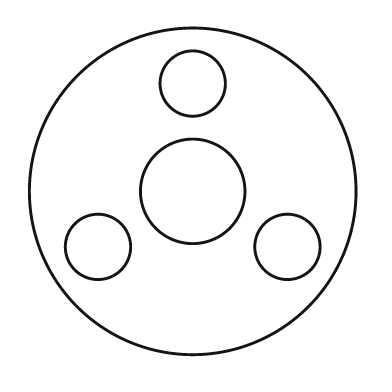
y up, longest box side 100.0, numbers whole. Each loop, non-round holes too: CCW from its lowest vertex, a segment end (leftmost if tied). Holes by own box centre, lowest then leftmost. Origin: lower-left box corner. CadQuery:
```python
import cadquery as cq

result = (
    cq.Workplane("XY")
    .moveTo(50.0, 50.0)
    .circle(50.0)
    .moveTo(21.0, 33.0)
    .circle(10.0)
    .moveTo(79.0, 33.0)
    .circle(10.0)
    .moveTo(50.0, 50.0)
    .circle(16.0)
    .moveTo(50.0, 83.0)
    .circle(10.0)
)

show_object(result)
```